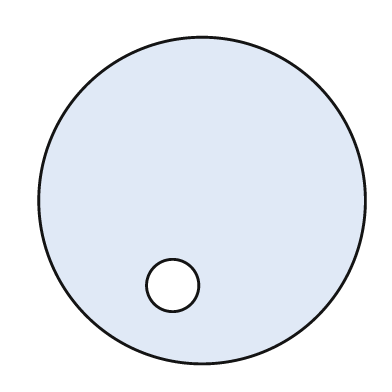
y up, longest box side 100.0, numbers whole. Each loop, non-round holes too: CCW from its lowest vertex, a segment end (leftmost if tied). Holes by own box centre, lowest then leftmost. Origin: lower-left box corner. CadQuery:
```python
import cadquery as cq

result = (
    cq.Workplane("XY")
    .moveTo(50.0, 50.0)
    .circle(50.0)
    .moveTo(41.0, 24.0)
    .circle(8.0)
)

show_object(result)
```